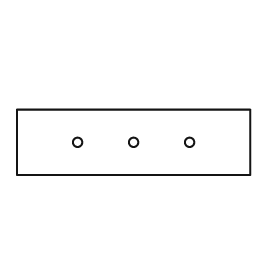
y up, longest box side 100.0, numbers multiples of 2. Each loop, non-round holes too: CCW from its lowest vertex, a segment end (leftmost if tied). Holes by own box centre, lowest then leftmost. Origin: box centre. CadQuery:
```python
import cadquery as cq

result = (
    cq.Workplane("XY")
    .moveTo(-50.0, -14.0)
    .lineTo(50.0, -14.0)
    .lineTo(50.0, 14.0)
    .lineTo(-50.0, 14.0)
    .close()
    .moveTo(-24.0, 0.0)
    .circle(2.0)
    .moveTo(0.0, 0.0)
    .circle(2.0)
    .moveTo(24.0, 0.0)
    .circle(2.0)
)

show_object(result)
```